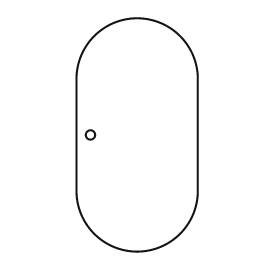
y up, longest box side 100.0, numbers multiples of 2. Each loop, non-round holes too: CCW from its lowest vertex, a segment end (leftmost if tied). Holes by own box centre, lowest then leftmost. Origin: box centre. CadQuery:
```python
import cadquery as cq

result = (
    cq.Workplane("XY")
    .moveTo(-26.0, -24.0)
    .threePointArc((0.0, -50.0), (26.0, -24.0))
    .lineTo(26.0, 24.0)
    .threePointArc((0.0, 50.0), (-26.0, 24.0))
    .close()
    .moveTo(-20.0, 0.0)
    .circle(2.0)
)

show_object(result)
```